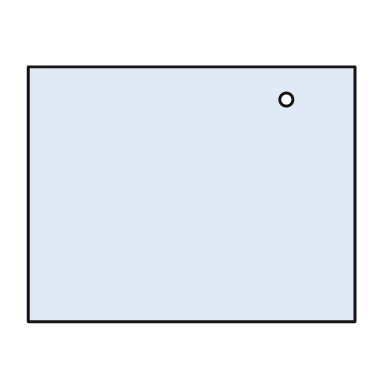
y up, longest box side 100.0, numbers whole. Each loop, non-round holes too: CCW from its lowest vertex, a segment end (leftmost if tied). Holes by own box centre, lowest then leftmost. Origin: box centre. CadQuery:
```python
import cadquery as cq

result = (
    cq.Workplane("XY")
    .moveTo(-50.0, -39.0)
    .lineTo(50.0, -39.0)
    .lineTo(50.0, 39.0)
    .lineTo(-50.0, 39.0)
    .close()
    .moveTo(29.0, 29.0)
    .circle(2.0)
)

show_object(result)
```